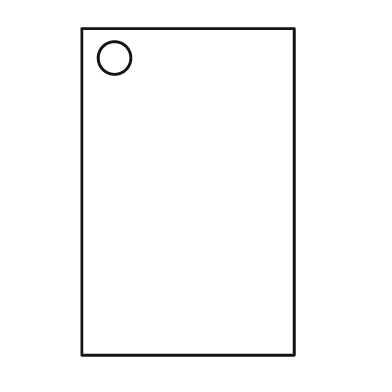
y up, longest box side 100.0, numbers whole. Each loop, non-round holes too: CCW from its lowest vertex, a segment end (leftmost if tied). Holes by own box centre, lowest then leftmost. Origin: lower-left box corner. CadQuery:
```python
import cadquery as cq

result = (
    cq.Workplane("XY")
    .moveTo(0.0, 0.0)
    .lineTo(65.0, 0.0)
    .lineTo(65.0, 100.0)
    .lineTo(0.0, 100.0)
    .close()
    .moveTo(10.0, 91.0)
    .circle(5.0)
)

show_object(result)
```